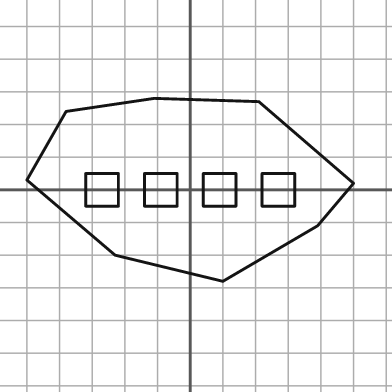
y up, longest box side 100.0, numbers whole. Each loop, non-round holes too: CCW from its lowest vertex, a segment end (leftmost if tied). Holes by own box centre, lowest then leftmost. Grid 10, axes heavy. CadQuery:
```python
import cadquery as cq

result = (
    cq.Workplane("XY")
    .moveTo(10.0, -28.0)
    .lineTo(39.0, -11.0)
    .lineTo(50.0, 2.0)
    .lineTo(21.0, 27.0)
    .lineTo(-11.0, 28.0)
    .lineTo(-38.0, 24.0)
    .lineTo(-50.0, 3.0)
    .lineTo(-23.0, -20.0)
    .close()
    .moveTo(-32.0, -5.0)
    .lineTo(-22.0, -5.0)
    .lineTo(-22.0, 5.0)
    .lineTo(-32.0, 5.0)
    .close()
    .moveTo(-14.0, -5.0)
    .lineTo(-4.0, -5.0)
    .lineTo(-4.0, 5.0)
    .lineTo(-14.0, 5.0)
    .close()
    .moveTo(4.0, -5.0)
    .lineTo(14.0, -5.0)
    .lineTo(14.0, 5.0)
    .lineTo(4.0, 5.0)
    .close()
    .moveTo(22.0, -5.0)
    .lineTo(32.0, -5.0)
    .lineTo(32.0, 5.0)
    .lineTo(22.0, 5.0)
    .close()
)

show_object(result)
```